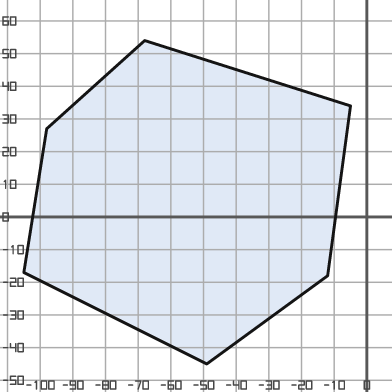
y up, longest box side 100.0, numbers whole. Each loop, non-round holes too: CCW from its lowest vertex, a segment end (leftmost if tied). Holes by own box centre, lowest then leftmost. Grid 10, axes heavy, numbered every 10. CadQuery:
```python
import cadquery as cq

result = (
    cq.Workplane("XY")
    .moveTo(-49.0, -45.0)
    .lineTo(-12.0, -18.0)
    .lineTo(-5.0, 34.0)
    .lineTo(-68.0, 54.0)
    .lineTo(-98.0, 27.0)
    .lineTo(-105.0, -17.0)
    .close()
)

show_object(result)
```